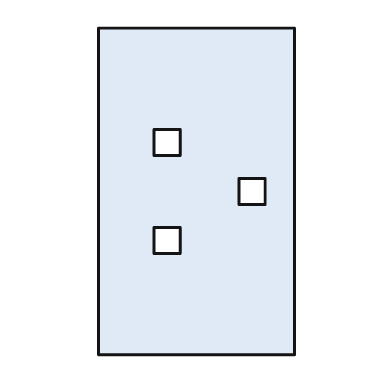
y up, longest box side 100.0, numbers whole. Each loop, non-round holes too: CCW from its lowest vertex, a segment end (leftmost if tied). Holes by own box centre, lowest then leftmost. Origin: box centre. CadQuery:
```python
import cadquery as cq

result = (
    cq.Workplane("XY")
    .moveTo(-30.0, -50.0)
    .lineTo(30.0, -50.0)
    .lineTo(30.0, 50.0)
    .lineTo(-30.0, 50.0)
    .close()
    .moveTo(-13.0, -19.0)
    .lineTo(-5.0, -19.0)
    .lineTo(-5.0, -11.0)
    .lineTo(-13.0, -11.0)
    .close()
    .moveTo(13.0, -4.0)
    .lineTo(21.0, -4.0)
    .lineTo(21.0, 4.0)
    .lineTo(13.0, 4.0)
    .close()
    .moveTo(-13.0, 11.0)
    .lineTo(-5.0, 11.0)
    .lineTo(-5.0, 19.0)
    .lineTo(-13.0, 19.0)
    .close()
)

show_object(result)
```